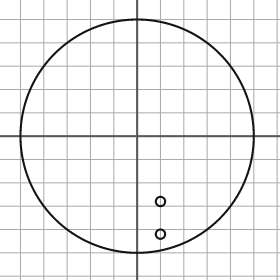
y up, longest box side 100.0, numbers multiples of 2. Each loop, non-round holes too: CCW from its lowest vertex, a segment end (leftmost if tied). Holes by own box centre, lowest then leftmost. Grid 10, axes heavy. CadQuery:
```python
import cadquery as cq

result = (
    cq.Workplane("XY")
    .moveTo(0.0, 0.0)
    .circle(50.0)
    .moveTo(10.0, -42.0)
    .circle(2.0)
    .moveTo(10.0, -28.0)
    .circle(2.0)
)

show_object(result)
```